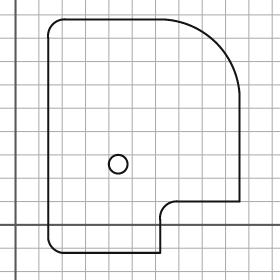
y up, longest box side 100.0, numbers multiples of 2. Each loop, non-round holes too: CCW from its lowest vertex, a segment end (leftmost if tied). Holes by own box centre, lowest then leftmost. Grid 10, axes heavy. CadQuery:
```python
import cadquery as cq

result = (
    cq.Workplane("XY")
    .moveTo(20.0, -12.0)
    .lineTo(62.0, -12.0)
    .lineTo(62.0, 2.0)
    .threePointArc((64.0, 8.0), (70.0, 10.0))
    .lineTo(96.0, 10.0)
    .lineTo(96.0, 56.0)
    .threePointArc((86.0, 78.0), (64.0, 88.0))
    .lineTo(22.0, 88.0)
    .threePointArc((16.0, 86.0), (14.0, 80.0))
    .lineTo(14.0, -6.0)
    .threePointArc((16.0, -10.0), (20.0, -12.0))
    .close()
    .moveTo(44.0, 26.0)
    .circle(4.0)
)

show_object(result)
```